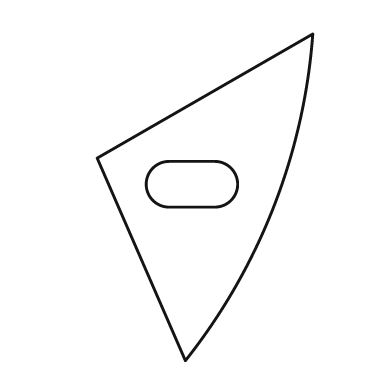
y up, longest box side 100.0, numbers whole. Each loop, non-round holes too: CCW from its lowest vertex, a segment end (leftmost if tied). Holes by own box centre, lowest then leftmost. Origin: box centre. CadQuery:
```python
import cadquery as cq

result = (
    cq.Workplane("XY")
    .moveTo(-6.0, -50.0)
    .threePointArc((21.0, -3.0), (33.0, 50.0))
    .lineTo(-33.0, 12.0)
    .close()
    .moveTo(-11.0, -3.0)
    .lineTo(3.0, -3.0)
    .threePointArc((10.0, 4.0), (3.0, 11.0))
    .lineTo(-11.0, 11.0)
    .threePointArc((-18.0, 4.0), (-11.0, -3.0))
    .close()
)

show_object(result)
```